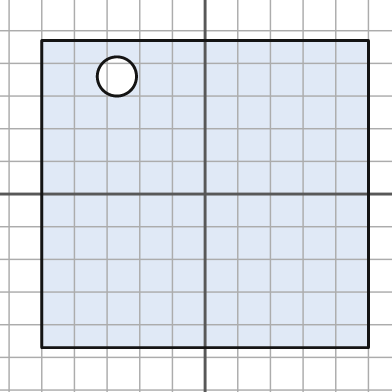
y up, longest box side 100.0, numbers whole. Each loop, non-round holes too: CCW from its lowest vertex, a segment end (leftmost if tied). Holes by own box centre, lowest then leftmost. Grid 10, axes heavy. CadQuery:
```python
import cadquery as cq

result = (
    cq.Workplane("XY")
    .moveTo(-50.0, -47.0)
    .lineTo(50.0, -47.0)
    .lineTo(50.0, 47.0)
    .lineTo(-50.0, 47.0)
    .close()
    .moveTo(-27.0, 36.0)
    .circle(6.0)
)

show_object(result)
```